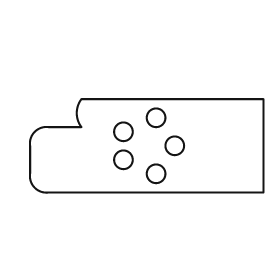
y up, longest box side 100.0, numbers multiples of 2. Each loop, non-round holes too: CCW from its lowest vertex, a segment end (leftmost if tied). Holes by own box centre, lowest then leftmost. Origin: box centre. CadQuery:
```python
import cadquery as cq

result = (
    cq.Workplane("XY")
    .moveTo(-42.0, -20.0)
    .lineTo(50.0, -20.0)
    .lineTo(50.0, 20.0)
    .lineTo(-28.0, 20.0)
    .threePointArc((-30.0, 14.0), (-28.0, 8.0))
    .lineTo(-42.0, 8.0)
    .threePointArc((-48.0, 6.0), (-50.0, 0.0))
    .lineTo(-50.0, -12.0)
    .threePointArc((-48.0, -18.0), (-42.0, -20.0))
    .close()
    .moveTo(4.0, -12.0)
    .circle(4.0)
    .moveTo(-10.0, -6.0)
    .circle(4.0)
    .moveTo(12.0, 0.0)
    .circle(4.0)
    .moveTo(-10.0, 6.0)
    .circle(4.0)
    .moveTo(4.0, 12.0)
    .circle(4.0)
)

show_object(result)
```